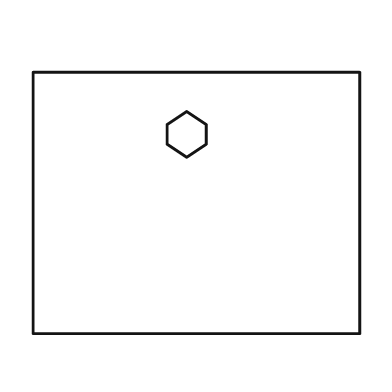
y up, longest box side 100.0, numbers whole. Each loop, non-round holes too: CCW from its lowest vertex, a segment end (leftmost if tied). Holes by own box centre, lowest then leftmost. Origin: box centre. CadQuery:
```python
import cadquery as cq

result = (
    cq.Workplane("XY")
    .moveTo(-50.0, -40.0)
    .lineTo(50.0, -40.0)
    .lineTo(50.0, 40.0)
    .lineTo(-50.0, 40.0)
    .close()
    .moveTo(-3.0, 14.0)
    .lineTo(3.0, 18.0)
    .lineTo(3.0, 24.0)
    .lineTo(-3.0, 28.0)
    .lineTo(-9.0, 24.0)
    .lineTo(-9.0, 18.0)
    .close()
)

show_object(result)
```